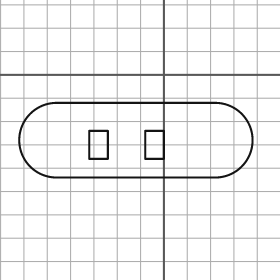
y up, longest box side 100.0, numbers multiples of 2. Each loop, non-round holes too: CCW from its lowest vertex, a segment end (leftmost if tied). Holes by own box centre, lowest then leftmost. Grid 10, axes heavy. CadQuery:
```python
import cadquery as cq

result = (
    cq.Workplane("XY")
    .moveTo(-46.0, -44.0)
    .lineTo(22.0, -44.0)
    .threePointArc((38.0, -28.0), (22.0, -12.0))
    .lineTo(-46.0, -12.0)
    .threePointArc((-62.0, -28.0), (-46.0, -44.0))
    .close()
    .moveTo(-32.0, -36.0)
    .lineTo(-24.0, -36.0)
    .lineTo(-24.0, -24.0)
    .lineTo(-32.0, -24.0)
    .close()
    .moveTo(-8.0, -36.0)
    .lineTo(0.0, -36.0)
    .lineTo(0.0, -24.0)
    .lineTo(-8.0, -24.0)
    .close()
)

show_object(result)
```